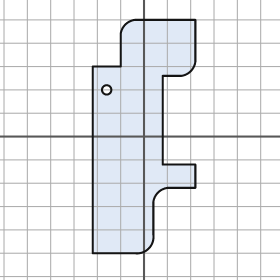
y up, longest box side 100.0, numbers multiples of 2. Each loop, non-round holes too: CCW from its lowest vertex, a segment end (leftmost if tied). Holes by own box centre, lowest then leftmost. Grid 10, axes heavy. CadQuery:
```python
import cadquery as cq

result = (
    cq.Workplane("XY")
    .moveTo(-22.0, -50.0)
    .lineTo(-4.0, -50.0)
    .threePointArc((2.0, -48.0), (4.0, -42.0))
    .lineTo(4.0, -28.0)
    .threePointArc((6.0, -24.0), (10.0, -22.0))
    .lineTo(22.0, -22.0)
    .lineTo(22.0, -12.0)
    .lineTo(8.0, -12.0)
    .lineTo(8.0, 26.0)
    .lineTo(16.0, 26.0)
    .threePointArc((20.0, 28.0), (22.0, 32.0))
    .lineTo(22.0, 50.0)
    .lineTo(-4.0, 50.0)
    .threePointArc((-8.0, 48.0), (-10.0, 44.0))
    .lineTo(-10.0, 30.0)
    .lineTo(-22.0, 30.0)
    .close()
    .moveTo(-16.0, 20.0)
    .circle(2.0)
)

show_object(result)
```